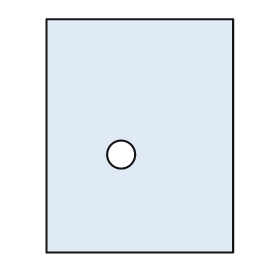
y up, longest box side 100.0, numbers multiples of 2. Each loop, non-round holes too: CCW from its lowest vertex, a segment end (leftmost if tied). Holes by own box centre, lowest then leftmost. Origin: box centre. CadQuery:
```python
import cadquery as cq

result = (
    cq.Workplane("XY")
    .moveTo(-40.0, -50.0)
    .lineTo(40.0, -50.0)
    .lineTo(40.0, 50.0)
    .lineTo(-40.0, 50.0)
    .close()
    .moveTo(-8.0, -8.0)
    .circle(6.0)
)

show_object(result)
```